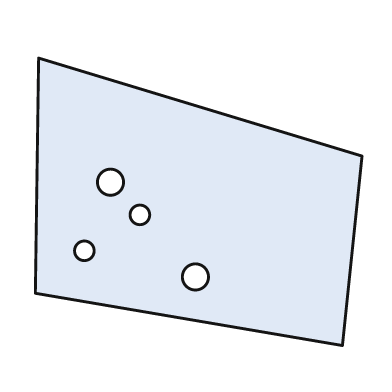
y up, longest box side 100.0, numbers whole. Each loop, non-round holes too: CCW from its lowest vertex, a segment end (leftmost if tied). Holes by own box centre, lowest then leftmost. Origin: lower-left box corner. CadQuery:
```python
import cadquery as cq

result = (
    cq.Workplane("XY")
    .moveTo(94.0, 0.0)
    .lineTo(100.0, 58.0)
    .lineTo(1.0, 88.0)
    .lineTo(0.0, 16.0)
    .close()
    .moveTo(49.0, 21.0)
    .circle(4.0)
    .moveTo(15.0, 29.0)
    .circle(3.0)
    .moveTo(32.0, 40.0)
    .circle(3.0)
    .moveTo(23.0, 50.0)
    .circle(4.0)
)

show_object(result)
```